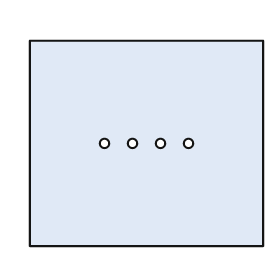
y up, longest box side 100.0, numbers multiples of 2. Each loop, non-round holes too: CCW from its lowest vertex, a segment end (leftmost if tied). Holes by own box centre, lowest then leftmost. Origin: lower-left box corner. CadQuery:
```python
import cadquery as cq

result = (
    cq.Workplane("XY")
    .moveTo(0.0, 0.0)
    .lineTo(100.0, 0.0)
    .lineTo(100.0, 88.0)
    .lineTo(0.0, 88.0)
    .close()
    .moveTo(32.0, 44.0)
    .circle(2.0)
    .moveTo(44.0, 44.0)
    .circle(2.0)
    .moveTo(56.0, 44.0)
    .circle(2.0)
    .moveTo(68.0, 44.0)
    .circle(2.0)
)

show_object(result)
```